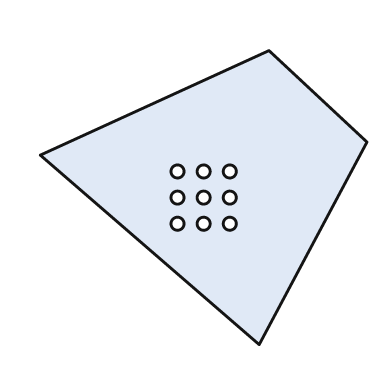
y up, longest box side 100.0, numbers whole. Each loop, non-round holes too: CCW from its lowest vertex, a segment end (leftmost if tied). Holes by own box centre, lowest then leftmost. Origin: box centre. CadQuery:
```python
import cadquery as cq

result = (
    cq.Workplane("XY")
    .moveTo(17.0, -45.0)
    .lineTo(50.0, 17.0)
    .lineTo(20.0, 45.0)
    .lineTo(-50.0, 13.0)
    .close()
    .moveTo(-8.0, -8.0)
    .circle(2.0)
    .moveTo(0.0, -8.0)
    .circle(2.0)
    .moveTo(8.0, -8.0)
    .circle(2.0)
    .moveTo(-8.0, 0.0)
    .circle(2.0)
    .moveTo(0.0, 0.0)
    .circle(2.0)
    .moveTo(8.0, 0.0)
    .circle(2.0)
    .moveTo(-8.0, 8.0)
    .circle(2.0)
    .moveTo(0.0, 8.0)
    .circle(2.0)
    .moveTo(8.0, 8.0)
    .circle(2.0)
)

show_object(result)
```